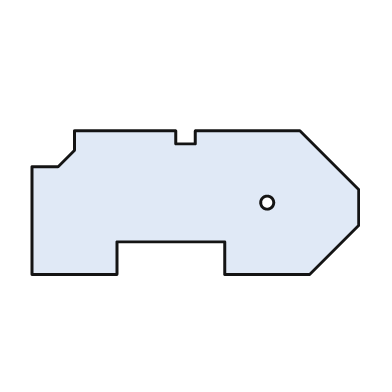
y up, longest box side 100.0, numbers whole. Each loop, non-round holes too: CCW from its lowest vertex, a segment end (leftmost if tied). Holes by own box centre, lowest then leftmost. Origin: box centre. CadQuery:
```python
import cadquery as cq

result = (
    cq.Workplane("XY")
    .moveTo(-50.0, -22.0)
    .lineTo(-24.0, -22.0)
    .lineTo(-24.0, -12.0)
    .lineTo(9.0, -12.0)
    .lineTo(9.0, -22.0)
    .lineTo(35.0, -22.0)
    .lineTo(50.0, -7.0)
    .lineTo(50.0, 4.0)
    .lineTo(32.0, 22.0)
    .lineTo(0.0, 22.0)
    .lineTo(0.0, 18.0)
    .lineTo(-6.0, 18.0)
    .lineTo(-6.0, 22.0)
    .lineTo(-37.0, 22.0)
    .lineTo(-37.0, 16.0)
    .lineTo(-42.0, 11.0)
    .lineTo(-50.0, 11.0)
    .close()
    .moveTo(22.0, 0.0)
    .circle(2.0)
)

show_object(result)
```